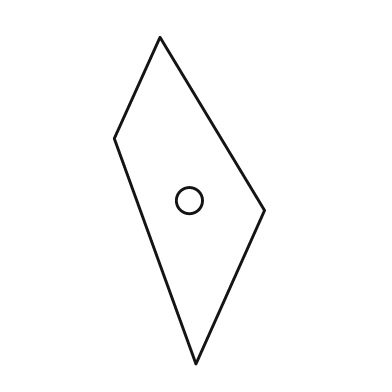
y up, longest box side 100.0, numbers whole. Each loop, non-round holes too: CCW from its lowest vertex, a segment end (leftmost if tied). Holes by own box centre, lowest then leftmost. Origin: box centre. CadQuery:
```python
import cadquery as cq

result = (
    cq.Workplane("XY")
    .moveTo(2.0, -50.0)
    .lineTo(23.0, -3.0)
    .lineTo(-9.0, 50.0)
    .lineTo(-23.0, 19.0)
    .close()
    .moveTo(0.0, 0.0)
    .circle(4.0)
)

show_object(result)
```